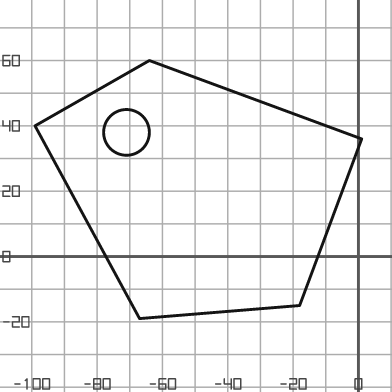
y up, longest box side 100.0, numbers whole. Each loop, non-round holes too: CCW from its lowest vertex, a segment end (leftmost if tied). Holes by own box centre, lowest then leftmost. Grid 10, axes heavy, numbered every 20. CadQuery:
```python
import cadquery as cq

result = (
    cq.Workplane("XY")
    .moveTo(-67.0, -19.0)
    .lineTo(-18.0, -15.0)
    .lineTo(1.0, 36.0)
    .lineTo(-64.0, 60.0)
    .lineTo(-99.0, 40.0)
    .close()
    .moveTo(-71.0, 38.0)
    .circle(7.0)
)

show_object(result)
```